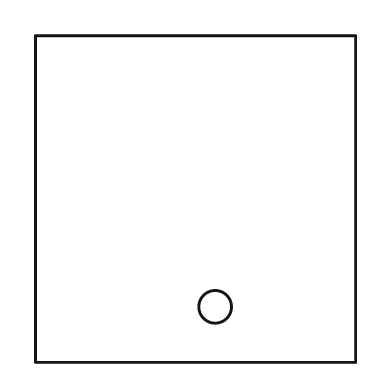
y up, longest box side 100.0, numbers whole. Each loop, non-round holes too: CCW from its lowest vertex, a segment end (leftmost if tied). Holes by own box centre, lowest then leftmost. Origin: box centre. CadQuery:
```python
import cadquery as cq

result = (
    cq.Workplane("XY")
    .moveTo(-49.0, -50.0)
    .lineTo(49.0, -50.0)
    .lineTo(49.0, 50.0)
    .lineTo(-49.0, 50.0)
    .close()
    .moveTo(6.0, -33.0)
    .circle(5.0)
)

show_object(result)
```